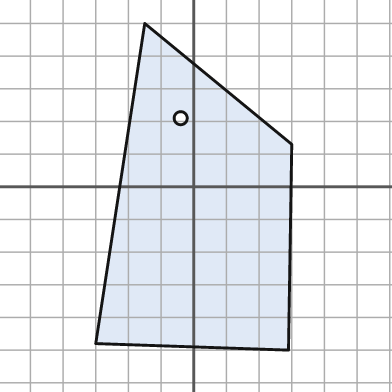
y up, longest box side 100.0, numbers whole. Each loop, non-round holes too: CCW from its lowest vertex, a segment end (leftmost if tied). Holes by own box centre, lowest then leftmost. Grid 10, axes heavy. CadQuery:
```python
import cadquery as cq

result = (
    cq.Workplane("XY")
    .moveTo(29.0, -50.0)
    .lineTo(30.0, 13.0)
    .lineTo(-15.0, 50.0)
    .lineTo(-30.0, -48.0)
    .close()
    .moveTo(-4.0, 21.0)
    .circle(2.0)
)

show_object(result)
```